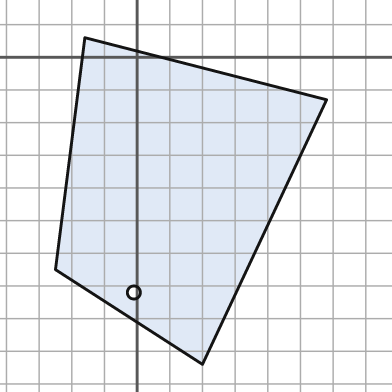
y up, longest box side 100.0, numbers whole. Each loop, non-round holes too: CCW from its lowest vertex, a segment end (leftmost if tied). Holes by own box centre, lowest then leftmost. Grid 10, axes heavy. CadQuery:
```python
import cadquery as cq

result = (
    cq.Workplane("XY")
    .moveTo(20.0, -94.0)
    .lineTo(58.0, -13.0)
    .lineTo(-16.0, 6.0)
    .lineTo(-25.0, -65.0)
    .close()
    .moveTo(-1.0, -72.0)
    .circle(2.0)
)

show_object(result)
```